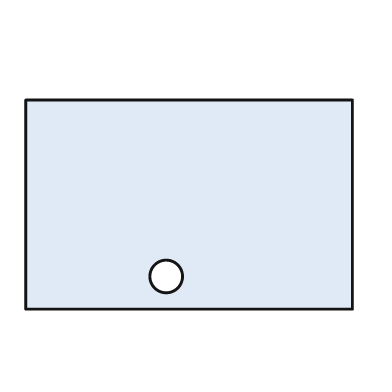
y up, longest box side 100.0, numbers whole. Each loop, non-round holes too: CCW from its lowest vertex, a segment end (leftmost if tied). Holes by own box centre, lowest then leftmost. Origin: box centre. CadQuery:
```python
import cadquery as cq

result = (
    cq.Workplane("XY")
    .moveTo(-50.0, -32.0)
    .lineTo(50.0, -32.0)
    .lineTo(50.0, 32.0)
    .lineTo(-50.0, 32.0)
    .close()
    .moveTo(-7.0, -22.0)
    .circle(5.0)
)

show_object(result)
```